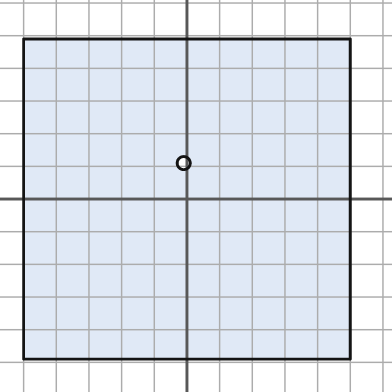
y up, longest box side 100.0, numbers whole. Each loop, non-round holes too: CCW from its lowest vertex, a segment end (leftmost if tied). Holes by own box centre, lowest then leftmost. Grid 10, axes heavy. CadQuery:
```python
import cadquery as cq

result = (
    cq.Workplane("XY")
    .moveTo(-50.0, -49.0)
    .lineTo(50.0, -49.0)
    .lineTo(50.0, 49.0)
    .lineTo(-50.0, 49.0)
    .close()
    .moveTo(-1.0, 11.0)
    .circle(2.0)
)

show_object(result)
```